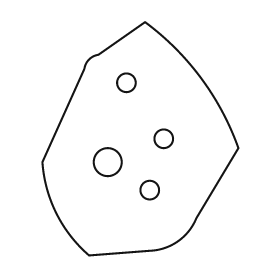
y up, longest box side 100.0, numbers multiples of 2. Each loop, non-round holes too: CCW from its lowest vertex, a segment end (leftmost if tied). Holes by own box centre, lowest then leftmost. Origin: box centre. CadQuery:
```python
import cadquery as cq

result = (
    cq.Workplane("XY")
    .moveTo(-22.0, -50.0)
    .lineTo(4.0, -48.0)
    .threePointArc((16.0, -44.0), (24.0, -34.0))
    .lineTo(42.0, -4.0)
    .threePointArc((26.0, 26.0), (2.0, 50.0))
    .lineTo(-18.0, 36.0)
    .threePointArc((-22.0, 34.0), (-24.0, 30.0))
    .lineTo(-42.0, -10.0)
    .threePointArc((-36.0, -32.0), (-22.0, -50.0))
    .close()
    .moveTo(4.0, -22.0)
    .circle(4.0)
    .moveTo(-14.0, -10.0)
    .circle(6.0)
    .moveTo(10.0, 0.0)
    .circle(4.0)
    .moveTo(-6.0, 24.0)
    .circle(4.0)
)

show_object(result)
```